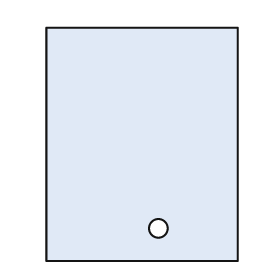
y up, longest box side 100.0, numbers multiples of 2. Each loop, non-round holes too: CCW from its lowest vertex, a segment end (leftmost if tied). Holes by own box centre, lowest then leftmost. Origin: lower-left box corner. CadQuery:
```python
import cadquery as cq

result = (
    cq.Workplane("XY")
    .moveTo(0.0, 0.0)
    .lineTo(82.0, 0.0)
    .lineTo(82.0, 100.0)
    .lineTo(0.0, 100.0)
    .close()
    .moveTo(48.0, 14.0)
    .circle(4.0)
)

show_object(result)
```